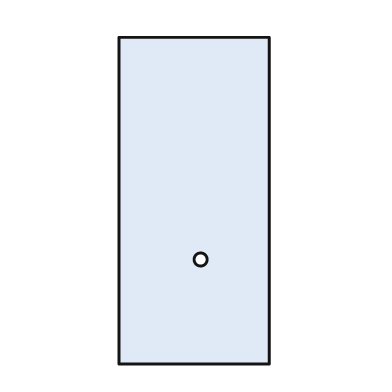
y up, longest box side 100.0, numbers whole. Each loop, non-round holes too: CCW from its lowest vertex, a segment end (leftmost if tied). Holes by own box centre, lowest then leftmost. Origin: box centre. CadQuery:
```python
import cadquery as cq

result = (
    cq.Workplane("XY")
    .moveTo(-23.0, -50.0)
    .lineTo(23.0, -50.0)
    .lineTo(23.0, 50.0)
    .lineTo(-23.0, 50.0)
    .close()
    .moveTo(2.0, -18.0)
    .circle(2.0)
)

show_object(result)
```